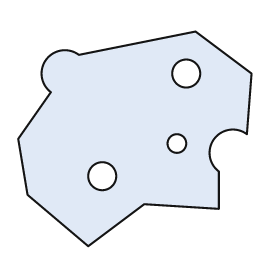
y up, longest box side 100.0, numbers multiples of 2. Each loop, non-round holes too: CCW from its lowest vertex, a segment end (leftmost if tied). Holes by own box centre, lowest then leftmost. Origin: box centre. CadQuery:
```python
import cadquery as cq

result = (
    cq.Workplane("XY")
    .moveTo(-20.0, -46.0)
    .lineTo(4.0, -28.0)
    .lineTo(36.0, -30.0)
    .lineTo(36.0, -14.0)
    .threePointArc((34.0, 0.0), (48.0, 2.0))
    .lineTo(50.0, 28.0)
    .lineTo(26.0, 46.0)
    .lineTo(-24.0, 36.0)
    .threePointArc((-38.0, 34.0), (-36.0, 20.0))
    .lineTo(-50.0, 0.0)
    .lineTo(-46.0, -24.0)
    .close()
    .moveTo(-14.0, -16.0)
    .circle(6.0)
    .moveTo(18.0, -2.0)
    .circle(4.0)
    .moveTo(22.0, 28.0)
    .circle(6.0)
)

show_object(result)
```